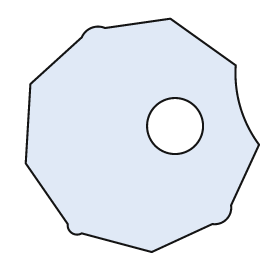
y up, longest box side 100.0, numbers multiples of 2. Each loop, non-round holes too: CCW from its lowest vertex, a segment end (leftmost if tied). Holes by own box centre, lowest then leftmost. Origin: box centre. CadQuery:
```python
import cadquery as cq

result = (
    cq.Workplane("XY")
    .moveTo(4.0, -50.0)
    .lineTo(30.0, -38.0)
    .threePointArc((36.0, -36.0), (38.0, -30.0))
    .lineTo(50.0, -4.0)
    .threePointArc((42.0, 12.0), (40.0, 30.0))
    .lineTo(12.0, 50.0)
    .lineTo(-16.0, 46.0)
    .threePointArc((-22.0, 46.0), (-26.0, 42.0))
    .lineTo(-48.0, 22.0)
    .lineTo(-50.0, -12.0)
    .lineTo(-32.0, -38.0)
    .threePointArc((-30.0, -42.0), (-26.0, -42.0))
    .close()
    .moveTo(14.0, 4.0)
    .circle(12.0)
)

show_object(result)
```